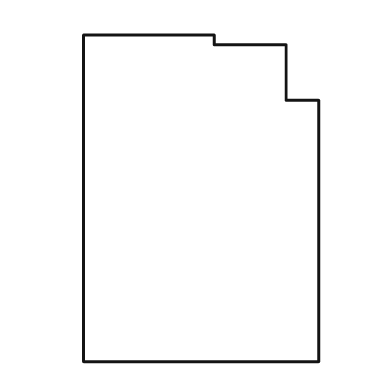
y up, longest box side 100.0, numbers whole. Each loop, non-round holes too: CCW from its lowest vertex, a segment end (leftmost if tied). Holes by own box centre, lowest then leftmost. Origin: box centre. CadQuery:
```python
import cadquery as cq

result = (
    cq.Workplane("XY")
    .moveTo(-36.0, -50.0)
    .lineTo(36.0, -50.0)
    .lineTo(36.0, 30.0)
    .lineTo(26.0, 30.0)
    .lineTo(26.0, 47.0)
    .lineTo(4.0, 47.0)
    .lineTo(4.0, 50.0)
    .lineTo(-36.0, 50.0)
    .close()
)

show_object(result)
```